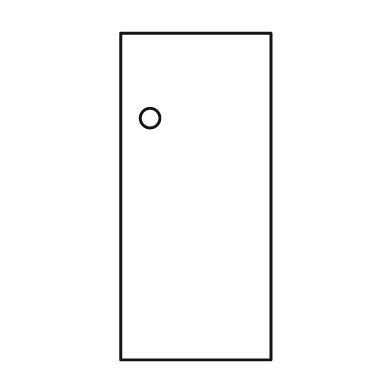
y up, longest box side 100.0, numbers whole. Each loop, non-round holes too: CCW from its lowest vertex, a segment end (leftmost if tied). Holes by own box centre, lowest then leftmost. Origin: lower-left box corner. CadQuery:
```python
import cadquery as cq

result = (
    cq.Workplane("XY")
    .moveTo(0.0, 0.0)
    .lineTo(46.0, 0.0)
    .lineTo(46.0, 100.0)
    .lineTo(0.0, 100.0)
    .close()
    .moveTo(9.0, 74.0)
    .circle(3.0)
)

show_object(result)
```